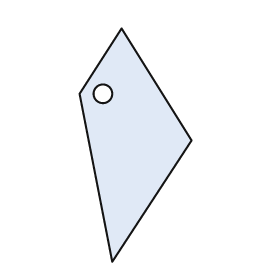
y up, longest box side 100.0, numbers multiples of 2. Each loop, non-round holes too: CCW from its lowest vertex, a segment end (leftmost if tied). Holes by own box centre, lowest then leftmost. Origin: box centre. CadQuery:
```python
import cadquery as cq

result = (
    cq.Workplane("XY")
    .moveTo(-10.0, -50.0)
    .lineTo(24.0, 2.0)
    .lineTo(-6.0, 50.0)
    .lineTo(-24.0, 22.0)
    .close()
    .moveTo(-14.0, 22.0)
    .circle(4.0)
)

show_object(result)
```